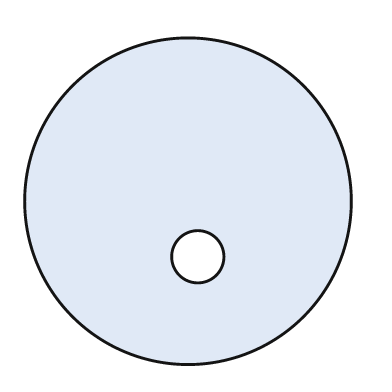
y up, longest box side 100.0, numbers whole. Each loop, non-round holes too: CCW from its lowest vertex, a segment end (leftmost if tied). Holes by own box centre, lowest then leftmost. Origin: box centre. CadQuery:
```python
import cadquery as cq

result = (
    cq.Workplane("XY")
    .moveTo(0.0, 0.0)
    .circle(50.0)
    .moveTo(3.0, -17.0)
    .circle(8.0)
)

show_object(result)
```